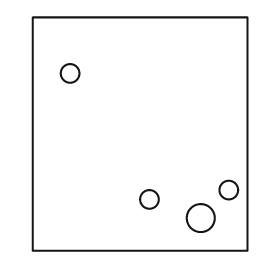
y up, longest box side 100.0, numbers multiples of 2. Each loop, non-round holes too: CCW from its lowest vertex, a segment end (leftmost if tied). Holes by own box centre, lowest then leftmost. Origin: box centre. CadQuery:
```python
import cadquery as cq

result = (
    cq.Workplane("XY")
    .moveTo(-46.0, -50.0)
    .lineTo(46.0, -50.0)
    .lineTo(46.0, 50.0)
    .lineTo(-46.0, 50.0)
    .close()
    .moveTo(26.0, -36.0)
    .circle(6.0)
    .moveTo(4.0, -28.0)
    .circle(4.0)
    .moveTo(38.0, -24.0)
    .circle(4.0)
    .moveTo(-30.0, 26.0)
    .circle(4.0)
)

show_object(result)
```